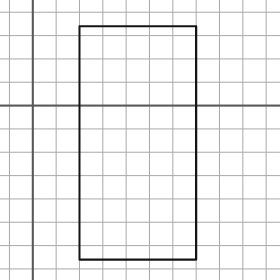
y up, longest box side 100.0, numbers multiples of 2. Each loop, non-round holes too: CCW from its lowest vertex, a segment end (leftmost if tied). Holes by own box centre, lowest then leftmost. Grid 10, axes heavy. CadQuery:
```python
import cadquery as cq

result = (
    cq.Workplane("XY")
    .moveTo(20.0, -66.0)
    .lineTo(70.0, -66.0)
    .lineTo(70.0, 34.0)
    .lineTo(20.0, 34.0)
    .close()
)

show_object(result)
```